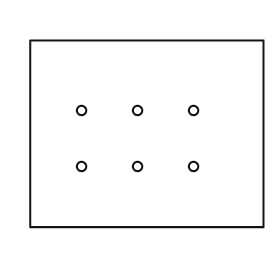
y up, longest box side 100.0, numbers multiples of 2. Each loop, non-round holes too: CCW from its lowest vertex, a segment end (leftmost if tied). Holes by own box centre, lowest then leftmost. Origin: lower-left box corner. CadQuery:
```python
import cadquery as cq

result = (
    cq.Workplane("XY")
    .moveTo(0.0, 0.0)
    .lineTo(100.0, 0.0)
    .lineTo(100.0, 80.0)
    .lineTo(0.0, 80.0)
    .close()
    .moveTo(22.0, 26.0)
    .circle(2.0)
    .moveTo(46.0, 26.0)
    .circle(2.0)
    .moveTo(70.0, 26.0)
    .circle(2.0)
    .moveTo(22.0, 50.0)
    .circle(2.0)
    .moveTo(46.0, 50.0)
    .circle(2.0)
    .moveTo(70.0, 50.0)
    .circle(2.0)
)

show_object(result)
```